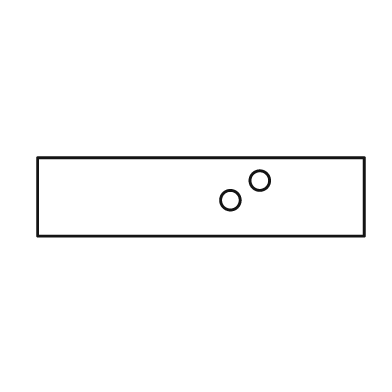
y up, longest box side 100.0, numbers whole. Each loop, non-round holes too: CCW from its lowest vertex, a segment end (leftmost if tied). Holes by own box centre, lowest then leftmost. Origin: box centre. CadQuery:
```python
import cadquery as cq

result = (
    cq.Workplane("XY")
    .moveTo(-50.0, -12.0)
    .lineTo(50.0, -12.0)
    .lineTo(50.0, 12.0)
    .lineTo(-50.0, 12.0)
    .close()
    .moveTo(9.0, -1.0)
    .circle(3.0)
    .moveTo(18.0, 5.0)
    .circle(3.0)
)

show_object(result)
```